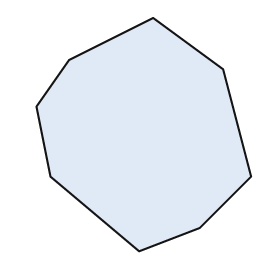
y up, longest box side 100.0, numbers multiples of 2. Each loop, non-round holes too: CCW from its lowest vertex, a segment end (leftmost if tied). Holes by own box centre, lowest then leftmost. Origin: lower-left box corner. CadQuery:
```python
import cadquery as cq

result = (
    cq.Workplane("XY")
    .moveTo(44.0, 0.0)
    .lineTo(70.0, 10.0)
    .lineTo(92.0, 32.0)
    .lineTo(80.0, 78.0)
    .lineTo(50.0, 100.0)
    .lineTo(14.0, 82.0)
    .lineTo(0.0, 62.0)
    .lineTo(6.0, 32.0)
    .close()
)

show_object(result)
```